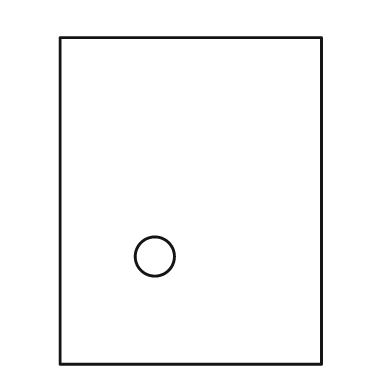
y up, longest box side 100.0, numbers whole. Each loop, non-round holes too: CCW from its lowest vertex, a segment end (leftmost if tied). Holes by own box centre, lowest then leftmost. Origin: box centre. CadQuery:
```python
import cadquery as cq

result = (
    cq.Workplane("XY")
    .moveTo(-40.0, -50.0)
    .lineTo(40.0, -50.0)
    .lineTo(40.0, 50.0)
    .lineTo(-40.0, 50.0)
    .close()
    .moveTo(-11.0, -17.0)
    .circle(6.0)
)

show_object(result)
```